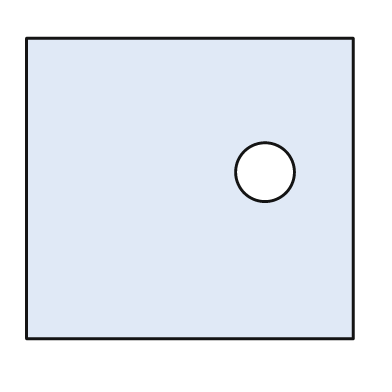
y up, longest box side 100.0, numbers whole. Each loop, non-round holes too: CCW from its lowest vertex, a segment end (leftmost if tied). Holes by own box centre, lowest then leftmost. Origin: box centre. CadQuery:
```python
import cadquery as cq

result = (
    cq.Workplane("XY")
    .moveTo(-50.0, -46.0)
    .lineTo(50.0, -46.0)
    .lineTo(50.0, 46.0)
    .lineTo(-50.0, 46.0)
    .close()
    .moveTo(23.0, 5.0)
    .circle(9.0)
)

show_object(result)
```